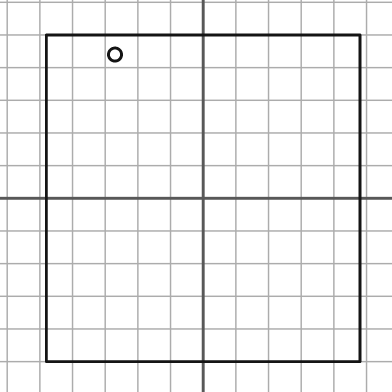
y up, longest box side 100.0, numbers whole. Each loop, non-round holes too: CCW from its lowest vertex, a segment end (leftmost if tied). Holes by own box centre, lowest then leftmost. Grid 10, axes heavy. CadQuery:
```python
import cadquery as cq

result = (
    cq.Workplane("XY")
    .moveTo(-48.0, -50.0)
    .lineTo(48.0, -50.0)
    .lineTo(48.0, 50.0)
    .lineTo(-48.0, 50.0)
    .close()
    .moveTo(-27.0, 44.0)
    .circle(2.0)
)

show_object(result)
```